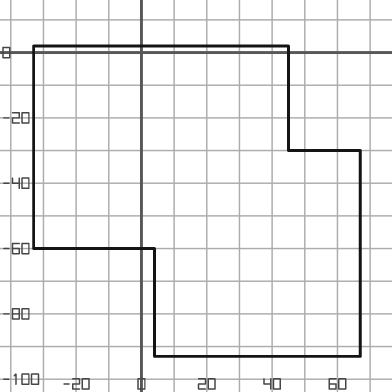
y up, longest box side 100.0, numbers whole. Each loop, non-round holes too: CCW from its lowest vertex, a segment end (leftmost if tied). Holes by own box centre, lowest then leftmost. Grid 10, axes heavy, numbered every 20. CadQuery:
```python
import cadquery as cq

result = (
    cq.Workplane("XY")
    .moveTo(4.0, -93.0)
    .lineTo(67.0, -93.0)
    .lineTo(67.0, -30.0)
    .lineTo(45.0, -30.0)
    .lineTo(45.0, 2.0)
    .lineTo(-33.0, 2.0)
    .lineTo(-33.0, -60.0)
    .lineTo(4.0, -60.0)
    .close()
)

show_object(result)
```